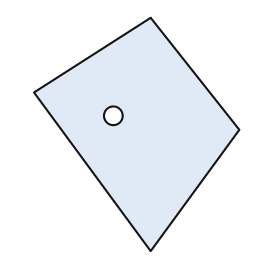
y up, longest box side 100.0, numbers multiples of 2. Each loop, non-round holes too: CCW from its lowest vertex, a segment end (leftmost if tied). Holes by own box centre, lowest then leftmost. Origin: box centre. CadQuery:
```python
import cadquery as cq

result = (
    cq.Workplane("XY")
    .moveTo(6.0, -50.0)
    .lineTo(44.0, 2.0)
    .lineTo(6.0, 50.0)
    .lineTo(-44.0, 18.0)
    .close()
    .moveTo(-10.0, 8.0)
    .circle(4.0)
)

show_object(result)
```